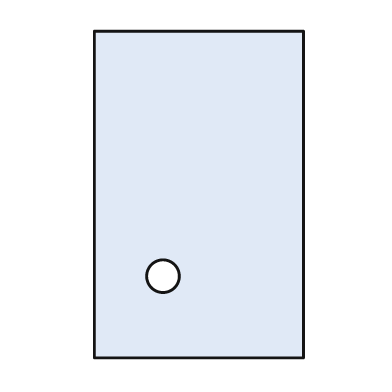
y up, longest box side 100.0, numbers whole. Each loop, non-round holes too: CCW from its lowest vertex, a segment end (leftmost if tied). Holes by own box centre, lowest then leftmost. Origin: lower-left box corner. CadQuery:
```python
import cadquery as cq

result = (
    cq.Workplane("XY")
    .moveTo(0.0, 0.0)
    .lineTo(64.0, 0.0)
    .lineTo(64.0, 100.0)
    .lineTo(0.0, 100.0)
    .close()
    .moveTo(21.0, 25.0)
    .circle(5.0)
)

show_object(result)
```